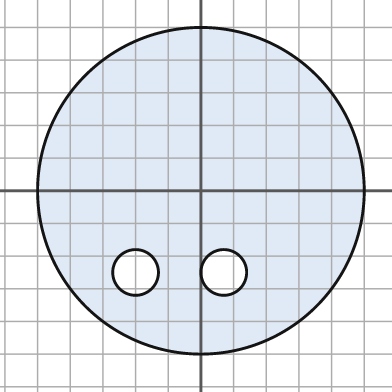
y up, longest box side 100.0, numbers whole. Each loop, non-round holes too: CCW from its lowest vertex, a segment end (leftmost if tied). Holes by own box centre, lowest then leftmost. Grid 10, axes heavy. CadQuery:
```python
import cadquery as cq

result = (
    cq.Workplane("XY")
    .moveTo(0.0, 0.0)
    .circle(50.0)
    .moveTo(-20.0, -25.0)
    .circle(7.0)
    .moveTo(7.0, -25.0)
    .circle(7.0)
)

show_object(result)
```